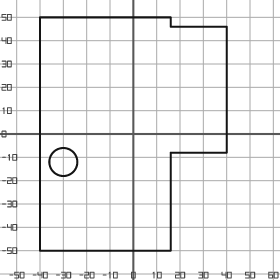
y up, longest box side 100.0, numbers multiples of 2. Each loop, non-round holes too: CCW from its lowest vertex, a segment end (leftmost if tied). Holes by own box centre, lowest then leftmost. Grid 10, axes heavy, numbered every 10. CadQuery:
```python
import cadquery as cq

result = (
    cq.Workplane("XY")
    .moveTo(-40.0, -50.0)
    .lineTo(16.0, -50.0)
    .lineTo(16.0, -8.0)
    .lineTo(40.0, -8.0)
    .lineTo(40.0, 46.0)
    .lineTo(16.0, 46.0)
    .lineTo(16.0, 50.0)
    .lineTo(-40.0, 50.0)
    .close()
    .moveTo(-30.0, -12.0)
    .circle(6.0)
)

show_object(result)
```